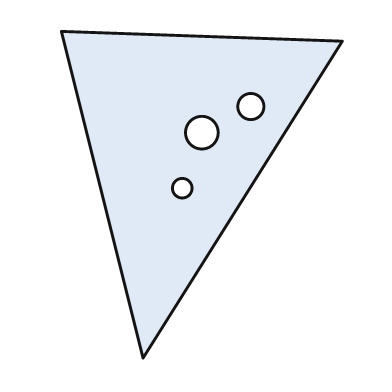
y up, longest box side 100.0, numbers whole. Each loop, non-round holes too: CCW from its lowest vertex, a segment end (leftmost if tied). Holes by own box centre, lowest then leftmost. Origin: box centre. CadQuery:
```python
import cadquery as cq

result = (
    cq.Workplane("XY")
    .moveTo(-18.0, -50.0)
    .lineTo(43.0, 47.0)
    .lineTo(-43.0, 50.0)
    .close()
    .moveTo(-6.0, 2.0)
    .circle(3.0)
    .moveTo(0.0, 19.0)
    .circle(5.0)
    .moveTo(15.0, 27.0)
    .circle(4.0)
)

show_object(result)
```